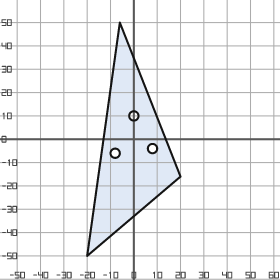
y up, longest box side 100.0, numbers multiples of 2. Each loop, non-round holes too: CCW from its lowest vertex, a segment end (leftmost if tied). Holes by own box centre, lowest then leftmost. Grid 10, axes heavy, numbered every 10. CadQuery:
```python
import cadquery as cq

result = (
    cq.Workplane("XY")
    .moveTo(-20.0, -50.0)
    .lineTo(20.0, -16.0)
    .lineTo(-6.0, 50.0)
    .close()
    .moveTo(-8.0, -6.0)
    .circle(2.0)
    .moveTo(8.0, -4.0)
    .circle(2.0)
    .moveTo(0.0, 10.0)
    .circle(2.0)
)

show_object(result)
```